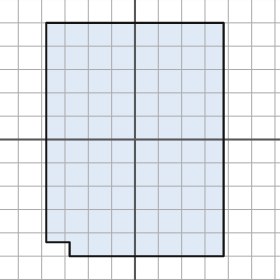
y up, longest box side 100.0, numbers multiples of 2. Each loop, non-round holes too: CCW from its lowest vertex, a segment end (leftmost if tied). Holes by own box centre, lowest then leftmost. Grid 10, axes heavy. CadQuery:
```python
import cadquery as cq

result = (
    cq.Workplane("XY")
    .moveTo(-28.0, -50.0)
    .lineTo(38.0, -50.0)
    .lineTo(38.0, 50.0)
    .lineTo(-38.0, 50.0)
    .lineTo(-38.0, -44.0)
    .lineTo(-28.0, -44.0)
    .close()
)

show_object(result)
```